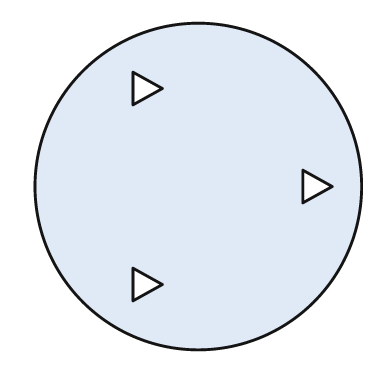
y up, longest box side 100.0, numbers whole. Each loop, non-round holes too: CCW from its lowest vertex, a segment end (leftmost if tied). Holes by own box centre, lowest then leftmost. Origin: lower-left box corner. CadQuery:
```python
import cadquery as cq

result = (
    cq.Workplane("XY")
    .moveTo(50.0, 50.0)
    .circle(50.0)
    .moveTo(30.0, 15.0)
    .lineTo(39.0, 20.0)
    .lineTo(30.0, 25.0)
    .close()
    .moveTo(82.0, 45.0)
    .lineTo(91.0, 50.0)
    .lineTo(82.0, 55.0)
    .close()
    .moveTo(30.0, 75.0)
    .lineTo(39.0, 80.0)
    .lineTo(30.0, 85.0)
    .close()
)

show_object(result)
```